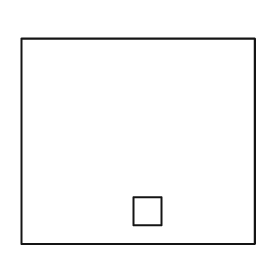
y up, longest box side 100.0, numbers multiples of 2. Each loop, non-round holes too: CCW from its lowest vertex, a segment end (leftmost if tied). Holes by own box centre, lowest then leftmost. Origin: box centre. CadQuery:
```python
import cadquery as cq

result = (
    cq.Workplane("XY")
    .moveTo(-50.0, -44.0)
    .lineTo(50.0, -44.0)
    .lineTo(50.0, 44.0)
    .lineTo(-50.0, 44.0)
    .close()
    .moveTo(-2.0, -36.0)
    .lineTo(10.0, -36.0)
    .lineTo(10.0, -24.0)
    .lineTo(-2.0, -24.0)
    .close()
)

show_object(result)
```